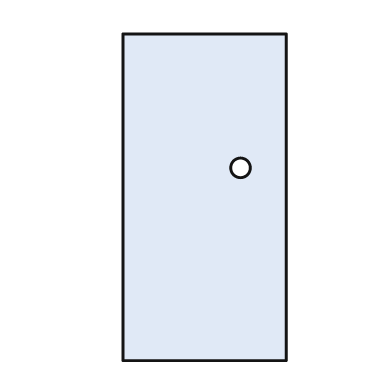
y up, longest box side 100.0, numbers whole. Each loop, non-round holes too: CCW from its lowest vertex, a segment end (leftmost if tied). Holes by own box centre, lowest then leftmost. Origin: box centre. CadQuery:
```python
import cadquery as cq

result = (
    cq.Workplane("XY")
    .moveTo(-25.0, -50.0)
    .lineTo(25.0, -50.0)
    .lineTo(25.0, 50.0)
    .lineTo(-25.0, 50.0)
    .close()
    .moveTo(11.0, 9.0)
    .circle(3.0)
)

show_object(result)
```